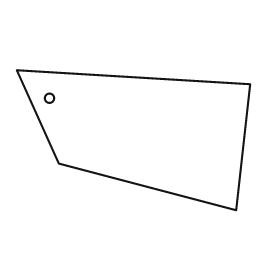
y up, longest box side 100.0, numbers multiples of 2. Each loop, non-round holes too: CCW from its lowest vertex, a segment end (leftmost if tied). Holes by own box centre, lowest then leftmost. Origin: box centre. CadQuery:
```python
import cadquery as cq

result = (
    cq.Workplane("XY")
    .moveTo(44.0, -30.0)
    .lineTo(50.0, 24.0)
    .lineTo(-50.0, 30.0)
    .lineTo(-32.0, -10.0)
    .close()
    .moveTo(-36.0, 18.0)
    .circle(2.0)
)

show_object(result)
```